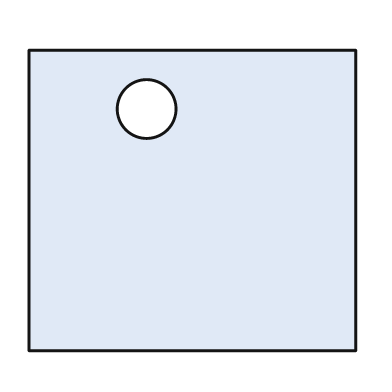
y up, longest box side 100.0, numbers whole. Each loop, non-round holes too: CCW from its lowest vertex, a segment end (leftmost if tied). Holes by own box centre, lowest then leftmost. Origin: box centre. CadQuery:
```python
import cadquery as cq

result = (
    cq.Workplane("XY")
    .moveTo(-50.0, -46.0)
    .lineTo(50.0, -46.0)
    .lineTo(50.0, 46.0)
    .lineTo(-50.0, 46.0)
    .close()
    .moveTo(-14.0, 28.0)
    .circle(9.0)
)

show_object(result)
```